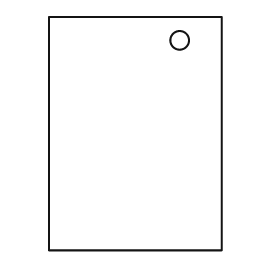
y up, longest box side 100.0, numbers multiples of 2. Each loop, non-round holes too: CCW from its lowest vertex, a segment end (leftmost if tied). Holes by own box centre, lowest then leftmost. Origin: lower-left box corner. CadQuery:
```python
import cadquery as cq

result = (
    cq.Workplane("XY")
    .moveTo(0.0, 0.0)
    .lineTo(74.0, 0.0)
    .lineTo(74.0, 100.0)
    .lineTo(0.0, 100.0)
    .close()
    .moveTo(56.0, 90.0)
    .circle(4.0)
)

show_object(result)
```